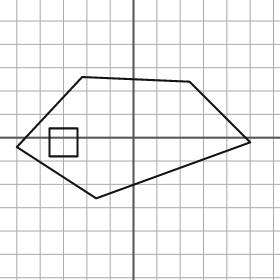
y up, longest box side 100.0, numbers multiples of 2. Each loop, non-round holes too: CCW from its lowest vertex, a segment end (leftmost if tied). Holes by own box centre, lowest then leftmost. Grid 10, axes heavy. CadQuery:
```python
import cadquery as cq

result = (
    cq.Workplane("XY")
    .moveTo(-16.0, -26.0)
    .lineTo(50.0, -2.0)
    .lineTo(24.0, 24.0)
    .lineTo(-22.0, 26.0)
    .lineTo(-50.0, -4.0)
    .close()
    .moveTo(-36.0, -8.0)
    .lineTo(-24.0, -8.0)
    .lineTo(-24.0, 4.0)
    .lineTo(-36.0, 4.0)
    .close()
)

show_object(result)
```